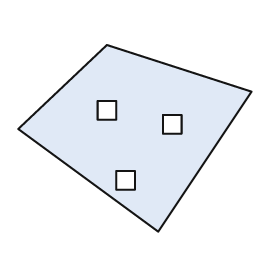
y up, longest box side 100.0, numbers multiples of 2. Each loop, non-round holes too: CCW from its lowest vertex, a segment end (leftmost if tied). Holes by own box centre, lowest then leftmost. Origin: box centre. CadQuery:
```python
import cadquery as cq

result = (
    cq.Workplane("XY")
    .moveTo(10.0, -40.0)
    .lineTo(50.0, 20.0)
    .lineTo(-12.0, 40.0)
    .lineTo(-50.0, 4.0)
    .close()
    .moveTo(-8.0, -22.0)
    .lineTo(0.0, -22.0)
    .lineTo(0.0, -14.0)
    .lineTo(-8.0, -14.0)
    .close()
    .moveTo(12.0, 2.0)
    .lineTo(20.0, 2.0)
    .lineTo(20.0, 10.0)
    .lineTo(12.0, 10.0)
    .close()
    .moveTo(-16.0, 8.0)
    .lineTo(-8.0, 8.0)
    .lineTo(-8.0, 16.0)
    .lineTo(-16.0, 16.0)
    .close()
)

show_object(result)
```